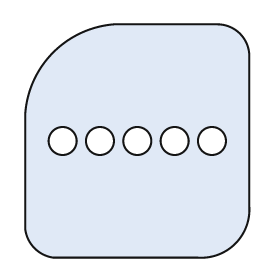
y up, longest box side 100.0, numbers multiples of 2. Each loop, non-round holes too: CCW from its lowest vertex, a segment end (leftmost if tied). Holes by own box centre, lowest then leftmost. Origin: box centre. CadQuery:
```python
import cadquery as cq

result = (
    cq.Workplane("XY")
    .moveTo(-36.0, -50.0)
    .lineTo(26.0, -50.0)
    .threePointArc((42.0, -44.0), (48.0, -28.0))
    .lineTo(48.0, 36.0)
    .threePointArc((44.0, 46.0), (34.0, 50.0))
    .lineTo(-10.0, 50.0)
    .threePointArc((-36.0, 38.0), (-48.0, 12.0))
    .lineTo(-48.0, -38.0)
    .threePointArc((-44.0, -46.0), (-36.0, -50.0))
    .close()
    .moveTo(-32.0, 0.0)
    .circle(6.0)
    .moveTo(-16.0, 0.0)
    .circle(6.0)
    .moveTo(0.0, 0.0)
    .circle(6.0)
    .moveTo(16.0, 0.0)
    .circle(6.0)
    .moveTo(32.0, 0.0)
    .circle(6.0)
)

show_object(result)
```